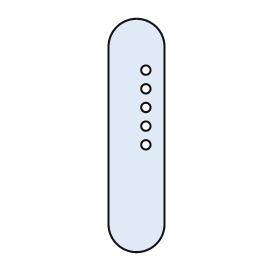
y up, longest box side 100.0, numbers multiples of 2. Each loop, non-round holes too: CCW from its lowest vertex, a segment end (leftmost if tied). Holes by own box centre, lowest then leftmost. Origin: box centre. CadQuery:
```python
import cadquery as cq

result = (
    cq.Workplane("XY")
    .moveTo(-12.0, -38.0)
    .threePointArc((0.0, -50.0), (12.0, -38.0))
    .lineTo(12.0, 38.0)
    .threePointArc((0.0, 50.0), (-12.0, 38.0))
    .close()
    .moveTo(4.0, -4.0)
    .circle(2.0)
    .moveTo(4.0, 4.0)
    .circle(2.0)
    .moveTo(4.0, 12.0)
    .circle(2.0)
    .moveTo(4.0, 20.0)
    .circle(2.0)
    .moveTo(4.0, 28.0)
    .circle(2.0)
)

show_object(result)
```